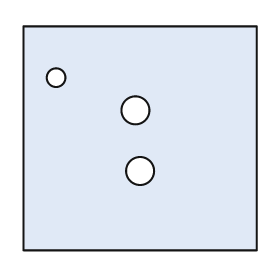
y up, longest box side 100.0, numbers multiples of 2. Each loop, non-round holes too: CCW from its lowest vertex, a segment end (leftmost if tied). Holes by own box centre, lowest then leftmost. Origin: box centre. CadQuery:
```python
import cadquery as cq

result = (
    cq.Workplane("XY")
    .moveTo(-50.0, -48.0)
    .lineTo(50.0, -48.0)
    .lineTo(50.0, 48.0)
    .lineTo(-50.0, 48.0)
    .close()
    .moveTo(0.0, -14.0)
    .circle(6.0)
    .moveTo(-2.0, 12.0)
    .circle(6.0)
    .moveTo(-36.0, 26.0)
    .circle(4.0)
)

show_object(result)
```